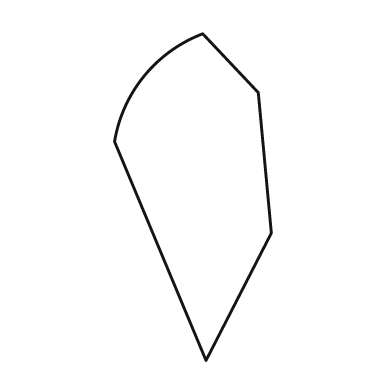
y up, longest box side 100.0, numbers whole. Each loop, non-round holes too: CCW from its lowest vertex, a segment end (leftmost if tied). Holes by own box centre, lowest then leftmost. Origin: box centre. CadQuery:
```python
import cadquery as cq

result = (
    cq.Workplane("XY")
    .moveTo(4.0, -50.0)
    .lineTo(24.0, -11.0)
    .lineTo(20.0, 32.0)
    .lineTo(3.0, 50.0)
    .threePointArc((-15.0, 37.0), (-24.0, 17.0))
    .close()
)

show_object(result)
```